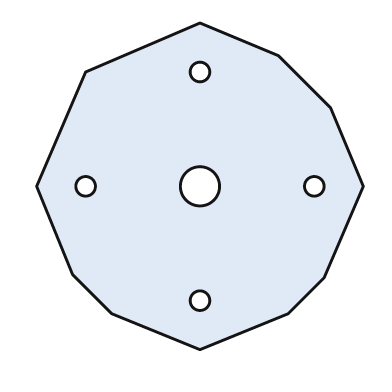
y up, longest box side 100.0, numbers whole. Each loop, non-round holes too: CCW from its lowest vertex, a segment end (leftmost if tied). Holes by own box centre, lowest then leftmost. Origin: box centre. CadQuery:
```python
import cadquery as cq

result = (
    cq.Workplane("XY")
    .moveTo(0.0, -50.0)
    .lineTo(27.0, -39.0)
    .lineTo(38.0, -28.0)
    .lineTo(50.0, 0.0)
    .lineTo(40.0, 24.0)
    .lineTo(24.0, 40.0)
    .lineTo(0.0, 50.0)
    .lineTo(-35.0, 35.0)
    .lineTo(-50.0, 0.0)
    .lineTo(-39.0, -27.0)
    .lineTo(-27.0, -39.0)
    .close()
    .moveTo(0.0, -35.0)
    .circle(3.0)
    .moveTo(-35.0, 0.0)
    .circle(3.0)
    .moveTo(0.0, 0.0)
    .circle(6.0)
    .moveTo(35.0, 0.0)
    .circle(3.0)
    .moveTo(0.0, 35.0)
    .circle(3.0)
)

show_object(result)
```